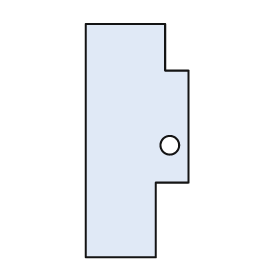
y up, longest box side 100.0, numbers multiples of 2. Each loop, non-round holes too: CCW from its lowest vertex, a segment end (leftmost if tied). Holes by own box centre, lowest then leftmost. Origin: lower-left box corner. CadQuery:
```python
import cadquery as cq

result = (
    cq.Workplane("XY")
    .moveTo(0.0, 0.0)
    .lineTo(30.0, 0.0)
    .lineTo(30.0, 32.0)
    .lineTo(44.0, 32.0)
    .lineTo(44.0, 80.0)
    .lineTo(34.0, 80.0)
    .lineTo(34.0, 100.0)
    .lineTo(0.0, 100.0)
    .close()
    .moveTo(36.0, 48.0)
    .circle(4.0)
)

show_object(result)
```